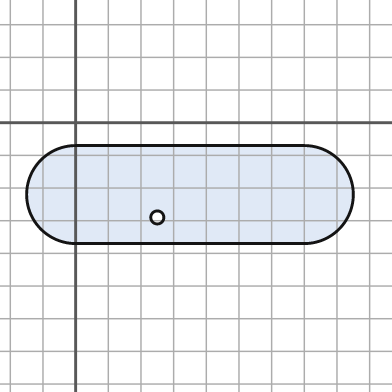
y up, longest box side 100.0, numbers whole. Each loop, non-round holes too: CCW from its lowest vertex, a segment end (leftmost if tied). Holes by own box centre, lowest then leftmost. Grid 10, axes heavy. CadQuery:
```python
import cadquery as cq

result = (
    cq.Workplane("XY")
    .moveTo(0.0, -37.0)
    .lineTo(70.0, -37.0)
    .threePointArc((85.0, -22.0), (70.0, -7.0))
    .lineTo(0.0, -7.0)
    .threePointArc((-15.0, -22.0), (0.0, -37.0))
    .close()
    .moveTo(25.0, -29.0)
    .circle(2.0)
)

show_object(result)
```